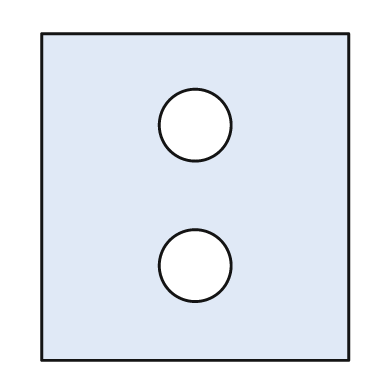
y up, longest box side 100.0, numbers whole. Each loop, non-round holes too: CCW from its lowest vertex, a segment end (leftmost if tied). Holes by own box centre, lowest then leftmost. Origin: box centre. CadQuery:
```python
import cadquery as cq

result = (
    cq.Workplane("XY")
    .moveTo(-47.0, -50.0)
    .lineTo(47.0, -50.0)
    .lineTo(47.0, 50.0)
    .lineTo(-47.0, 50.0)
    .close()
    .moveTo(0.0, -21.0)
    .circle(11.0)
    .moveTo(0.0, 22.0)
    .circle(11.0)
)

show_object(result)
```